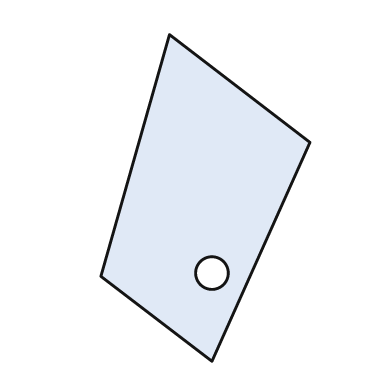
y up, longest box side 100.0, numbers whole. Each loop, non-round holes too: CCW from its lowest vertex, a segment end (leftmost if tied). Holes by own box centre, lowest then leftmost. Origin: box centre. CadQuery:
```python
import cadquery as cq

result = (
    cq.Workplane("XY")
    .moveTo(2.0, -50.0)
    .lineTo(32.0, 17.0)
    .lineTo(-11.0, 50.0)
    .lineTo(-32.0, -24.0)
    .close()
    .moveTo(2.0, -23.0)
    .circle(5.0)
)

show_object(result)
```